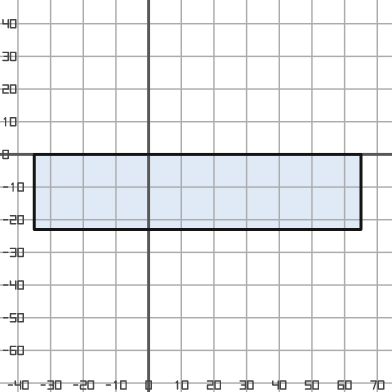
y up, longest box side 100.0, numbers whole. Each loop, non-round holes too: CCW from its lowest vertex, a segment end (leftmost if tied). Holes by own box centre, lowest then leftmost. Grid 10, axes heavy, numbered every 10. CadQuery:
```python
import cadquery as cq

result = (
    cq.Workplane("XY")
    .moveTo(-35.0, -23.0)
    .lineTo(65.0, -23.0)
    .lineTo(65.0, 0.0)
    .lineTo(-35.0, 0.0)
    .close()
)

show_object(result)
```